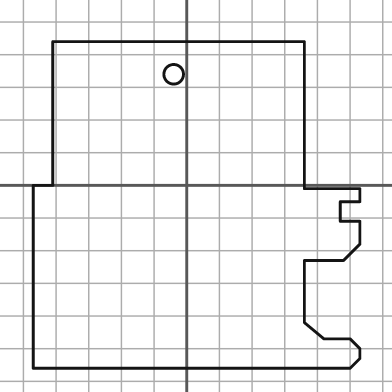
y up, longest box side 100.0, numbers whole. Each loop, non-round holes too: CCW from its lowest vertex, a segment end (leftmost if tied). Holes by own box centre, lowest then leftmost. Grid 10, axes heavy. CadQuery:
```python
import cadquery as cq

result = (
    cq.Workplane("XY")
    .moveTo(-47.0, -56.0)
    .lineTo(50.0, -56.0)
    .lineTo(53.0, -53.0)
    .lineTo(53.0, -50.0)
    .lineTo(50.0, -47.0)
    .lineTo(42.0, -47.0)
    .lineTo(36.0, -42.0)
    .lineTo(36.0, -23.0)
    .lineTo(48.0, -23.0)
    .lineTo(53.0, -18.0)
    .lineTo(53.0, -11.0)
    .lineTo(47.0, -11.0)
    .lineTo(47.0, -5.0)
    .lineTo(53.0, -5.0)
    .lineTo(53.0, -1.0)
    .lineTo(36.0, -1.0)
    .lineTo(36.0, 44.0)
    .lineTo(-41.0, 44.0)
    .lineTo(-41.0, 0.0)
    .lineTo(-47.0, 0.0)
    .close()
    .moveTo(-4.0, 34.0)
    .circle(3.0)
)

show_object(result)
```